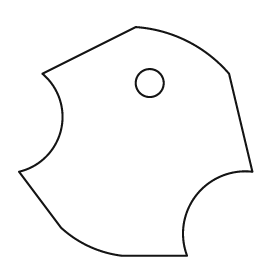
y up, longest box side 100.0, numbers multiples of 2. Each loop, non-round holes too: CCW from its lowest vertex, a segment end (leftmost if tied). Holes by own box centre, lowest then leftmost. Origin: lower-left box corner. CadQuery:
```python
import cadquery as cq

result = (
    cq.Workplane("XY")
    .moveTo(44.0, 0.0)
    .lineTo(72.0, 0.0)
    .threePointArc((76.0, 26.0), (100.0, 36.0))
    .lineTo(90.0, 78.0)
    .threePointArc((72.0, 92.0), (50.0, 98.0))
    .lineTo(10.0, 78.0)
    .threePointArc((18.0, 54.0), (0.0, 36.0))
    .lineTo(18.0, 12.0)
    .threePointArc((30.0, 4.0), (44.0, 0.0))
    .close()
    .moveTo(56.0, 74.0)
    .circle(6.0)
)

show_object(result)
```